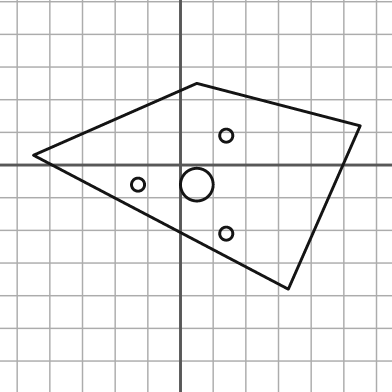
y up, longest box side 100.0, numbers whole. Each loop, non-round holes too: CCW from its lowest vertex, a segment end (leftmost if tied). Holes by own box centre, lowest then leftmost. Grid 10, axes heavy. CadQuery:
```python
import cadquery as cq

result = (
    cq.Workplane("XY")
    .moveTo(33.0, -38.0)
    .lineTo(55.0, 12.0)
    .lineTo(5.0, 25.0)
    .lineTo(-45.0, 3.0)
    .close()
    .moveTo(14.0, -21.0)
    .circle(2.0)
    .moveTo(-13.0, -6.0)
    .circle(2.0)
    .moveTo(5.0, -6.0)
    .circle(5.0)
    .moveTo(14.0, 9.0)
    .circle(2.0)
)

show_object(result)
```